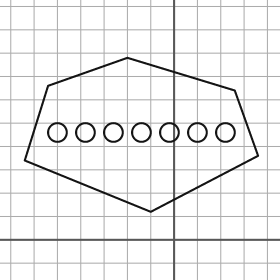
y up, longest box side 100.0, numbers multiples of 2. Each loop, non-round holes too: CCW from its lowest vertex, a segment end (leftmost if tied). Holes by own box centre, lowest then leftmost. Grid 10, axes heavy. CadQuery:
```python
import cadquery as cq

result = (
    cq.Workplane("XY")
    .moveTo(-10.0, 12.0)
    .lineTo(36.0, 36.0)
    .lineTo(26.0, 64.0)
    .lineTo(-20.0, 78.0)
    .lineTo(-54.0, 66.0)
    .lineTo(-64.0, 34.0)
    .close()
    .moveTo(-50.0, 46.0)
    .circle(4.0)
    .moveTo(-38.0, 46.0)
    .circle(4.0)
    .moveTo(-26.0, 46.0)
    .circle(4.0)
    .moveTo(-14.0, 46.0)
    .circle(4.0)
    .moveTo(-2.0, 46.0)
    .circle(4.0)
    .moveTo(10.0, 46.0)
    .circle(4.0)
    .moveTo(22.0, 46.0)
    .circle(4.0)
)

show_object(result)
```